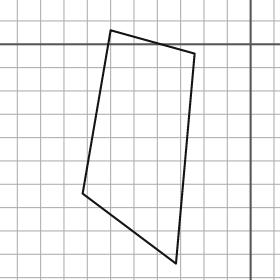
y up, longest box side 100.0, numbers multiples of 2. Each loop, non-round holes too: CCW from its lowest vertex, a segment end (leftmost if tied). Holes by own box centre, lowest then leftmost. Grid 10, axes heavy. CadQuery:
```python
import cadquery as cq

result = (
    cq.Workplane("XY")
    .moveTo(-32.0, -94.0)
    .lineTo(-24.0, -4.0)
    .lineTo(-60.0, 6.0)
    .lineTo(-72.0, -64.0)
    .close()
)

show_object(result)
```